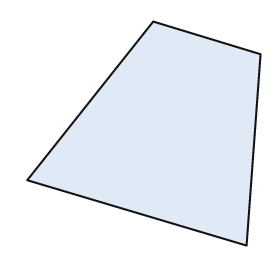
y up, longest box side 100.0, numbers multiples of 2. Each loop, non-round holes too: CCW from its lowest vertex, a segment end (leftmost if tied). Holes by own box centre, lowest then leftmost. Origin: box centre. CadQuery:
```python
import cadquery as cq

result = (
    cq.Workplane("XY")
    .moveTo(44.0, -48.0)
    .lineTo(50.0, 34.0)
    .lineTo(4.0, 48.0)
    .lineTo(-50.0, -20.0)
    .close()
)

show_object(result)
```